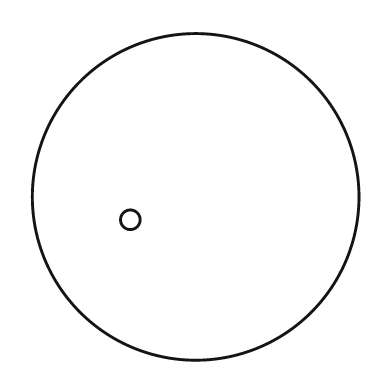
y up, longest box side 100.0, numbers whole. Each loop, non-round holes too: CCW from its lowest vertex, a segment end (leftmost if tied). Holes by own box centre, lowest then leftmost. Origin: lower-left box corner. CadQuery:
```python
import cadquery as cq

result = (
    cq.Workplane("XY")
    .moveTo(50.0, 50.0)
    .circle(50.0)
    .moveTo(30.0, 43.0)
    .circle(3.0)
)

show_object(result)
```